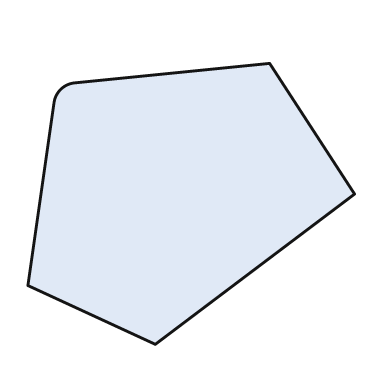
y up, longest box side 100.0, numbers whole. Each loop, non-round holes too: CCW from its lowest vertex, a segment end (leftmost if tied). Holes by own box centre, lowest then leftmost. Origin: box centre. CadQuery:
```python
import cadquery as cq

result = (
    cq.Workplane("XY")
    .moveTo(-11.0, -43.0)
    .lineTo(50.0, 3.0)
    .lineTo(24.0, 43.0)
    .lineTo(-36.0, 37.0)
    .threePointArc((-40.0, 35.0), (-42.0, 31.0))
    .lineTo(-50.0, -25.0)
    .close()
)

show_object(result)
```